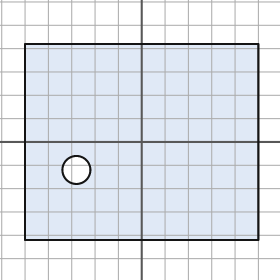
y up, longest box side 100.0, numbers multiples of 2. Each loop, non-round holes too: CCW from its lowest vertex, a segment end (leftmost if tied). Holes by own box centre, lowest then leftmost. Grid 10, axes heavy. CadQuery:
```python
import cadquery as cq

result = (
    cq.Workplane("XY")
    .moveTo(-50.0, -42.0)
    .lineTo(50.0, -42.0)
    .lineTo(50.0, 42.0)
    .lineTo(-50.0, 42.0)
    .close()
    .moveTo(-28.0, -12.0)
    .circle(6.0)
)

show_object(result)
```